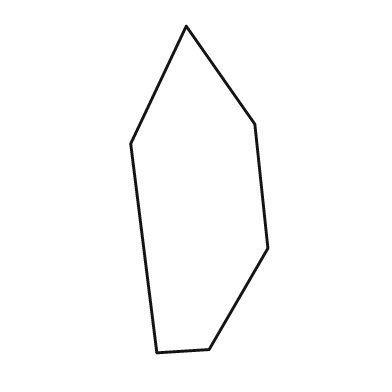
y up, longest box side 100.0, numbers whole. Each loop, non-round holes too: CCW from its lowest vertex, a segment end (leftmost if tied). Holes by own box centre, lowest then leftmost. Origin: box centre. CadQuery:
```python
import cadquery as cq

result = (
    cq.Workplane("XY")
    .moveTo(-13.0, -50.0)
    .lineTo(3.0, -49.0)
    .lineTo(21.0, -18.0)
    .lineTo(17.0, 20.0)
    .lineTo(-4.0, 50.0)
    .lineTo(-21.0, 14.0)
    .close()
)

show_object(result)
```